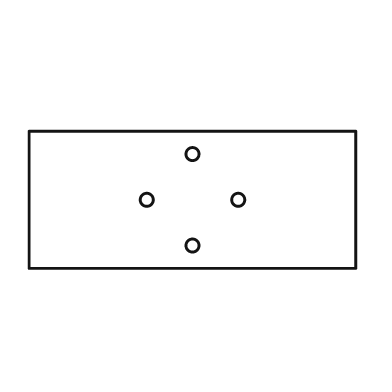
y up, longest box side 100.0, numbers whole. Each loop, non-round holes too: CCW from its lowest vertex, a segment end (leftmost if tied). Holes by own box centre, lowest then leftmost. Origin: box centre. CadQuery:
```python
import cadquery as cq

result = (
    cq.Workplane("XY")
    .moveTo(-50.0, -21.0)
    .lineTo(50.0, -21.0)
    .lineTo(50.0, 21.0)
    .lineTo(-50.0, 21.0)
    .close()
    .moveTo(0.0, -14.0)
    .circle(2.0)
    .moveTo(-14.0, 0.0)
    .circle(2.0)
    .moveTo(14.0, 0.0)
    .circle(2.0)
    .moveTo(0.0, 14.0)
    .circle(2.0)
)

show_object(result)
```